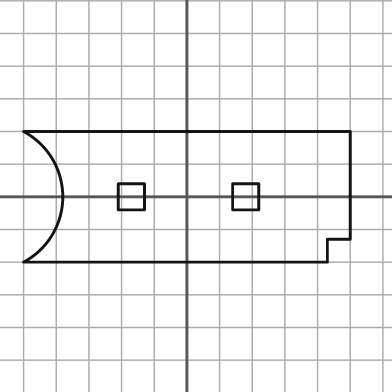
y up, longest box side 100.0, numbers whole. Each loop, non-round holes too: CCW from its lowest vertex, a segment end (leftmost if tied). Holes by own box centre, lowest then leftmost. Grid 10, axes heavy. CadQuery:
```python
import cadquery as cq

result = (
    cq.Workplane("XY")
    .moveTo(-50.0, -20.0)
    .lineTo(43.0, -20.0)
    .lineTo(43.0, -13.0)
    .lineTo(50.0, -13.0)
    .lineTo(50.0, 20.0)
    .lineTo(-50.0, 20.0)
    .threePointArc((-38.0, 0.0), (-50.0, -20.0))
    .close()
    .moveTo(-21.0, -4.0)
    .lineTo(-13.0, -4.0)
    .lineTo(-13.0, 4.0)
    .lineTo(-21.0, 4.0)
    .close()
    .moveTo(14.0, -4.0)
    .lineTo(22.0, -4.0)
    .lineTo(22.0, 4.0)
    .lineTo(14.0, 4.0)
    .close()
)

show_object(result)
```